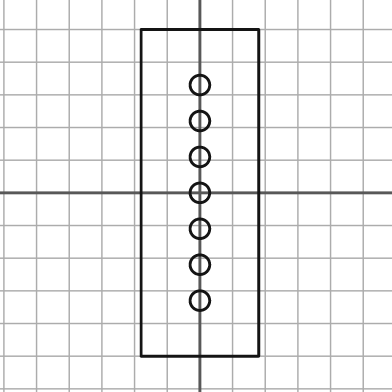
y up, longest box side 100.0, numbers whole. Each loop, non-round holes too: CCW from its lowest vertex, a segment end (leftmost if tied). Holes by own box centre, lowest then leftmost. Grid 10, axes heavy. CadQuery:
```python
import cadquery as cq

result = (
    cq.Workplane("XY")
    .moveTo(-18.0, -50.0)
    .lineTo(18.0, -50.0)
    .lineTo(18.0, 50.0)
    .lineTo(-18.0, 50.0)
    .close()
    .moveTo(0.0, -33.0)
    .circle(3.0)
    .moveTo(0.0, -22.0)
    .circle(3.0)
    .moveTo(0.0, -11.0)
    .circle(3.0)
    .moveTo(0.0, 0.0)
    .circle(3.0)
    .moveTo(0.0, 11.0)
    .circle(3.0)
    .moveTo(0.0, 22.0)
    .circle(3.0)
    .moveTo(0.0, 33.0)
    .circle(3.0)
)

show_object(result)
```